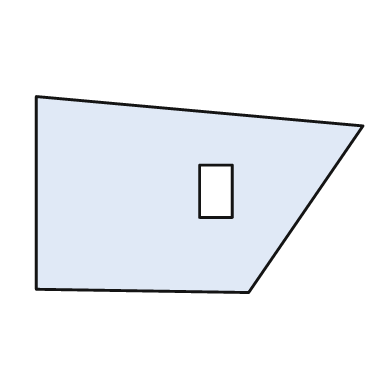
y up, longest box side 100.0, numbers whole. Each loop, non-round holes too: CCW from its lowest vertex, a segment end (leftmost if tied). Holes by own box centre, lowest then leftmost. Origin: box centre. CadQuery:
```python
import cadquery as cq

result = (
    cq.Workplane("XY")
    .moveTo(15.0, -30.0)
    .lineTo(50.0, 21.0)
    .lineTo(-50.0, 30.0)
    .lineTo(-50.0, -29.0)
    .close()
    .moveTo(0.0, -7.0)
    .lineTo(10.0, -7.0)
    .lineTo(10.0, 9.0)
    .lineTo(0.0, 9.0)
    .close()
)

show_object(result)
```